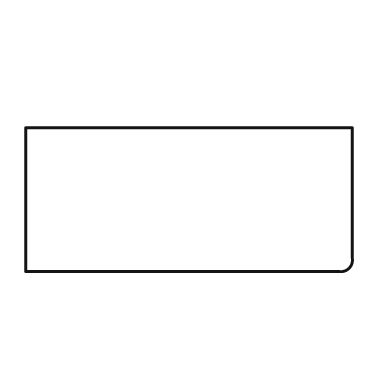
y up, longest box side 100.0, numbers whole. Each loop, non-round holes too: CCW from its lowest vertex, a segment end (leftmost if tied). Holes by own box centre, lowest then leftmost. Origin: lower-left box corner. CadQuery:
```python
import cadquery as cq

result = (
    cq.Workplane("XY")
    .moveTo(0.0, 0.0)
    .lineTo(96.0, 0.0)
    .threePointArc((99.0, 1.0), (100.0, 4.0))
    .lineTo(100.0, 44.0)
    .lineTo(0.0, 44.0)
    .close()
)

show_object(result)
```